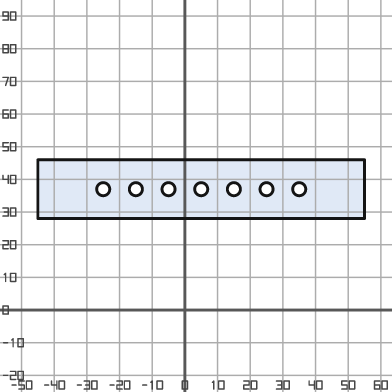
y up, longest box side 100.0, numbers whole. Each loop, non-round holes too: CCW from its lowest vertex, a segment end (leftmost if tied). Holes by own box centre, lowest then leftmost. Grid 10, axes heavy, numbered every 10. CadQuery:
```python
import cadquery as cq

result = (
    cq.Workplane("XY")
    .moveTo(-45.0, 28.0)
    .lineTo(55.0, 28.0)
    .lineTo(55.0, 46.0)
    .lineTo(-45.0, 46.0)
    .close()
    .moveTo(-25.0, 37.0)
    .circle(2.0)
    .moveTo(-15.0, 37.0)
    .circle(2.0)
    .moveTo(-5.0, 37.0)
    .circle(2.0)
    .moveTo(5.0, 37.0)
    .circle(2.0)
    .moveTo(15.0, 37.0)
    .circle(2.0)
    .moveTo(25.0, 37.0)
    .circle(2.0)
    .moveTo(35.0, 37.0)
    .circle(2.0)
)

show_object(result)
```